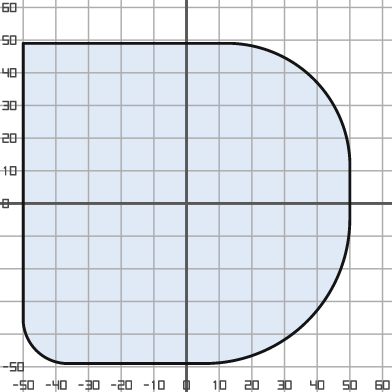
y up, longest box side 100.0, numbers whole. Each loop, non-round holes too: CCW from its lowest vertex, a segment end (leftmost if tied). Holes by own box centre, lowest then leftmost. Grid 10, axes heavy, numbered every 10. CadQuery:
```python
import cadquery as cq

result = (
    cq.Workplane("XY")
    .moveTo(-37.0, -49.0)
    .lineTo(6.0, -49.0)
    .threePointArc((37.0, -36.0), (50.0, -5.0))
    .lineTo(50.0, 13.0)
    .threePointArc((39.0, 38.0), (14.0, 49.0))
    .lineTo(-50.0, 49.0)
    .lineTo(-50.0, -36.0)
    .threePointArc((-46.0, -45.0), (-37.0, -49.0))
    .close()
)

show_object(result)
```